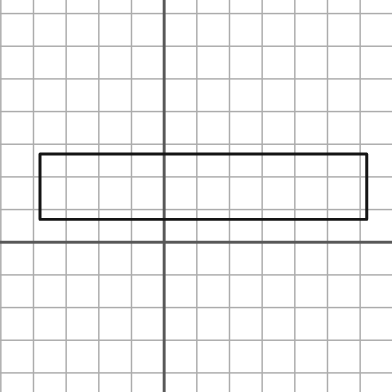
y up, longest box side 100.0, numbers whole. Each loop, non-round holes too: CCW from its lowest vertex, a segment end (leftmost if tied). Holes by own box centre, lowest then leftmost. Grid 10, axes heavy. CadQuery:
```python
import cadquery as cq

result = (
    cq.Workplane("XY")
    .moveTo(-38.0, 7.0)
    .lineTo(62.0, 7.0)
    .lineTo(62.0, 27.0)
    .lineTo(-38.0, 27.0)
    .close()
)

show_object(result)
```